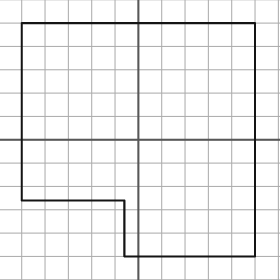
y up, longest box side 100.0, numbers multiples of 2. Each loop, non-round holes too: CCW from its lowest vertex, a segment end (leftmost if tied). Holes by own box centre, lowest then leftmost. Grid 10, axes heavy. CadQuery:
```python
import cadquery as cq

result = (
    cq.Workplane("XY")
    .moveTo(-6.0, -50.0)
    .lineTo(50.0, -50.0)
    .lineTo(50.0, 50.0)
    .lineTo(-50.0, 50.0)
    .lineTo(-50.0, -26.0)
    .lineTo(-6.0, -26.0)
    .close()
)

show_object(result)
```